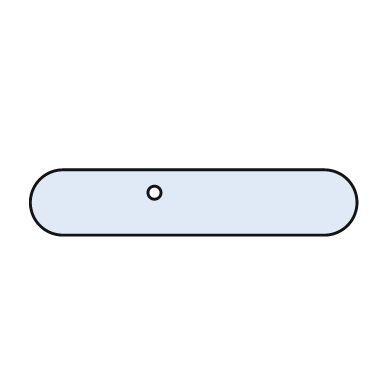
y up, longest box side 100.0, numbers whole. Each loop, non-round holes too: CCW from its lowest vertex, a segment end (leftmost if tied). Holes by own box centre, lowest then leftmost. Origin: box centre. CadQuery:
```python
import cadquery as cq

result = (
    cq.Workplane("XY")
    .moveTo(-40.0, -10.0)
    .lineTo(40.0, -10.0)
    .threePointArc((50.0, 0.0), (40.0, 10.0))
    .lineTo(-40.0, 10.0)
    .threePointArc((-50.0, 0.0), (-40.0, -10.0))
    .close()
    .moveTo(-12.0, 3.0)
    .circle(2.0)
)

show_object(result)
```